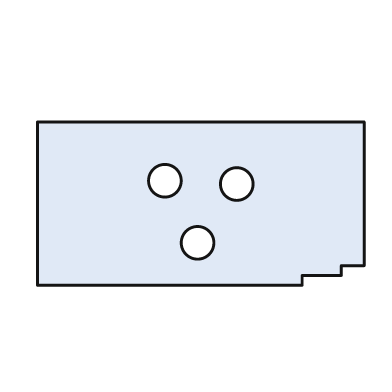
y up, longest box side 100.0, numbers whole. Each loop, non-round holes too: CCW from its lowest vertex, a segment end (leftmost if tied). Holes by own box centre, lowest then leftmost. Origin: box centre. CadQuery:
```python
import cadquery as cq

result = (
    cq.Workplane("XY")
    .moveTo(-50.0, -25.0)
    .lineTo(31.0, -25.0)
    .lineTo(31.0, -22.0)
    .lineTo(43.0, -22.0)
    .lineTo(43.0, -19.0)
    .lineTo(50.0, -19.0)
    .lineTo(50.0, 25.0)
    .lineTo(-50.0, 25.0)
    .close()
    .moveTo(-1.0, -12.0)
    .circle(5.0)
    .moveTo(11.0, 6.0)
    .circle(5.0)
    .moveTo(-11.0, 7.0)
    .circle(5.0)
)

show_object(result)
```